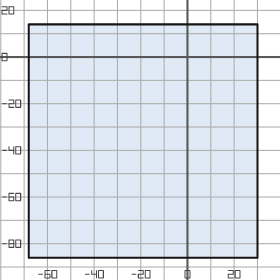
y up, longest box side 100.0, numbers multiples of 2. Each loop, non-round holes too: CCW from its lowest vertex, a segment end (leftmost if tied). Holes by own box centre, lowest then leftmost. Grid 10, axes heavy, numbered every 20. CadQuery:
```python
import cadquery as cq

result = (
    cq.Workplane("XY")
    .moveTo(-68.0, -86.0)
    .lineTo(30.0, -86.0)
    .lineTo(30.0, 14.0)
    .lineTo(-68.0, 14.0)
    .close()
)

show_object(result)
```